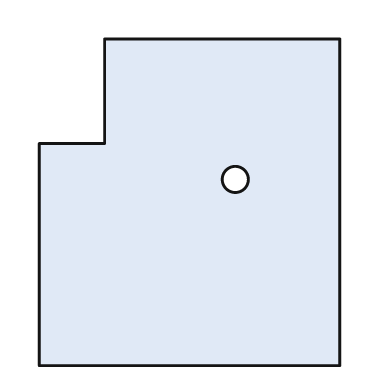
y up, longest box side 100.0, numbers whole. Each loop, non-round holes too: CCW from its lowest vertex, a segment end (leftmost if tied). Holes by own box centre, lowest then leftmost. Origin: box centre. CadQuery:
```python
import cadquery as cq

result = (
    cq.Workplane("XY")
    .moveTo(-46.0, -50.0)
    .lineTo(46.0, -50.0)
    .lineTo(46.0, 50.0)
    .lineTo(-26.0, 50.0)
    .lineTo(-26.0, 18.0)
    .lineTo(-46.0, 18.0)
    .close()
    .moveTo(14.0, 7.0)
    .circle(4.0)
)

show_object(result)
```